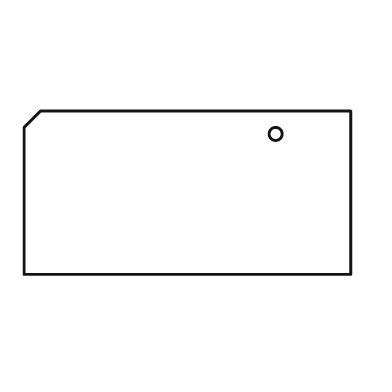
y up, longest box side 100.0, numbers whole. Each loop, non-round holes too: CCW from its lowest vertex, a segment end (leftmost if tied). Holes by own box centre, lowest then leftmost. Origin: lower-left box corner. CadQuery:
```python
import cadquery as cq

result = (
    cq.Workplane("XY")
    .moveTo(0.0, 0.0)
    .lineTo(100.0, 0.0)
    .lineTo(100.0, 50.0)
    .lineTo(5.0, 50.0)
    .lineTo(0.0, 45.0)
    .close()
    .moveTo(77.0, 43.0)
    .circle(2.0)
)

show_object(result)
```